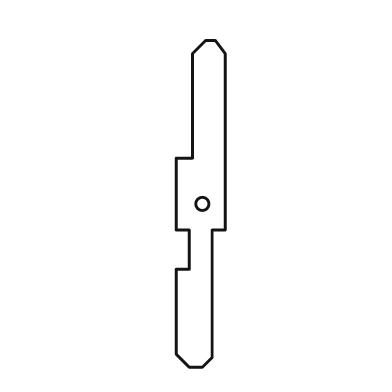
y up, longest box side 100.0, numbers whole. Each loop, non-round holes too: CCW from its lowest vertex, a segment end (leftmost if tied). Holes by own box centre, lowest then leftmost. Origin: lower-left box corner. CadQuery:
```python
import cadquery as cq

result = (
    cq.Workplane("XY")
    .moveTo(4.0, 0.0)
    .lineTo(8.0, 0.0)
    .lineTo(11.0, 3.0)
    .lineTo(11.0, 42.0)
    .lineTo(15.0, 42.0)
    .lineTo(15.0, 96.0)
    .lineTo(12.0, 100.0)
    .lineTo(9.0, 100.0)
    .lineTo(5.0, 96.0)
    .lineTo(5.0, 64.0)
    .lineTo(0.0, 64.0)
    .lineTo(0.0, 42.0)
    .lineTo(4.0, 42.0)
    .lineTo(4.0, 30.0)
    .lineTo(0.0, 30.0)
    .lineTo(0.0, 4.0)
    .close()
    .moveTo(8.0, 50.0)
    .circle(2.0)
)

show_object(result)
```